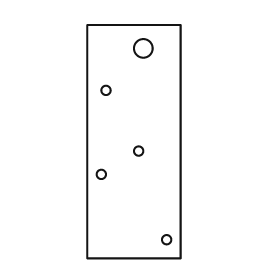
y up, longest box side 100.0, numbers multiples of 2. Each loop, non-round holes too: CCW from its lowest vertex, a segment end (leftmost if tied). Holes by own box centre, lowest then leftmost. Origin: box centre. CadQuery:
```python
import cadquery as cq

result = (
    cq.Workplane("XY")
    .moveTo(-20.0, -50.0)
    .lineTo(20.0, -50.0)
    .lineTo(20.0, 50.0)
    .lineTo(-20.0, 50.0)
    .close()
    .moveTo(14.0, -42.0)
    .circle(2.0)
    .moveTo(-14.0, -14.0)
    .circle(2.0)
    .moveTo(2.0, -4.0)
    .circle(2.0)
    .moveTo(-12.0, 22.0)
    .circle(2.0)
    .moveTo(4.0, 40.0)
    .circle(4.0)
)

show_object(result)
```